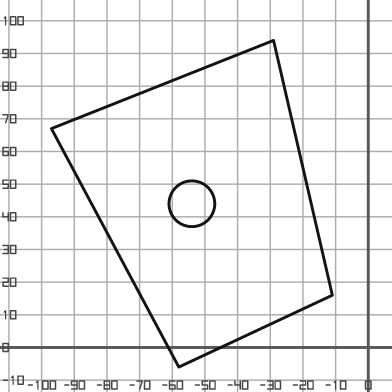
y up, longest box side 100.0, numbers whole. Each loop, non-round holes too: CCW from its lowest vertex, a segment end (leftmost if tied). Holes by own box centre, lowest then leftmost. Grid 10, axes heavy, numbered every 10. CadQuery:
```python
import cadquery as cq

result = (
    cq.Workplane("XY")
    .moveTo(-58.0, -6.0)
    .lineTo(-11.0, 16.0)
    .lineTo(-29.0, 94.0)
    .lineTo(-97.0, 67.0)
    .close()
    .moveTo(-54.0, 44.0)
    .circle(7.0)
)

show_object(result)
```